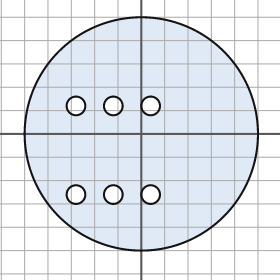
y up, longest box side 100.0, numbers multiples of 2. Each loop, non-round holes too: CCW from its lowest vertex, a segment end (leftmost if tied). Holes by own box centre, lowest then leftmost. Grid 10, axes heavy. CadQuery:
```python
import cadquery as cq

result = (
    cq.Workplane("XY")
    .moveTo(0.0, 0.0)
    .circle(50.0)
    .moveTo(-28.0, -26.0)
    .circle(4.0)
    .moveTo(-12.0, -26.0)
    .circle(4.0)
    .moveTo(4.0, -26.0)
    .circle(4.0)
    .moveTo(-28.0, 12.0)
    .circle(4.0)
    .moveTo(-12.0, 12.0)
    .circle(4.0)
    .moveTo(4.0, 12.0)
    .circle(4.0)
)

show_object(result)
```